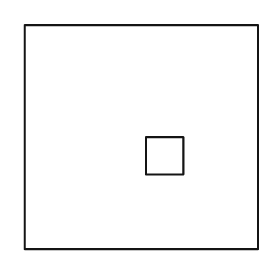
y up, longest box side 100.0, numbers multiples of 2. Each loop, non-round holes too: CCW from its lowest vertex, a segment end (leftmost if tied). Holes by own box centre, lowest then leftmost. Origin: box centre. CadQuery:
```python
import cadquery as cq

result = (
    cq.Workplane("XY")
    .moveTo(-50.0, -48.0)
    .lineTo(50.0, -48.0)
    .lineTo(50.0, 48.0)
    .lineTo(-50.0, 48.0)
    .close()
    .moveTo(2.0, -16.0)
    .lineTo(18.0, -16.0)
    .lineTo(18.0, 0.0)
    .lineTo(2.0, 0.0)
    .close()
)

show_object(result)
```